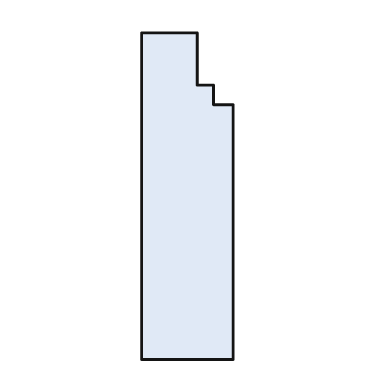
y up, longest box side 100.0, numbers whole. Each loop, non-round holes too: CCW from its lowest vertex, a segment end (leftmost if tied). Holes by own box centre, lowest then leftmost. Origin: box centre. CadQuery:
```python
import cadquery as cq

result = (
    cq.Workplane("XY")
    .moveTo(-14.0, -50.0)
    .lineTo(14.0, -50.0)
    .lineTo(14.0, 28.0)
    .lineTo(8.0, 28.0)
    .lineTo(8.0, 34.0)
    .lineTo(3.0, 34.0)
    .lineTo(3.0, 50.0)
    .lineTo(-14.0, 50.0)
    .close()
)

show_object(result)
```